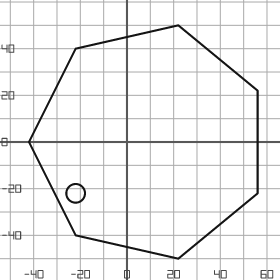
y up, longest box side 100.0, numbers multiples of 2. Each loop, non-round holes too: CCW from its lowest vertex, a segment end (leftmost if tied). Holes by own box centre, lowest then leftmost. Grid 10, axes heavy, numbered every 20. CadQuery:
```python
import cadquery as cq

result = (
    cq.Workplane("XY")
    .moveTo(22.0, -50.0)
    .lineTo(56.0, -22.0)
    .lineTo(56.0, 22.0)
    .lineTo(22.0, 50.0)
    .lineTo(-22.0, 40.0)
    .lineTo(-42.0, 0.0)
    .lineTo(-22.0, -40.0)
    .close()
    .moveTo(-22.0, -22.0)
    .circle(4.0)
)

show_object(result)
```